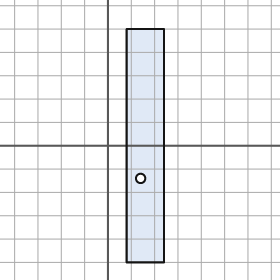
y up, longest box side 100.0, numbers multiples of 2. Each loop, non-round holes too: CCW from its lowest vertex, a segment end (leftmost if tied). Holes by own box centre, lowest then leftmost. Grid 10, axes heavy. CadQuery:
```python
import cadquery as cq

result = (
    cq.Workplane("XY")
    .moveTo(8.0, -50.0)
    .lineTo(24.0, -50.0)
    .lineTo(24.0, 50.0)
    .lineTo(8.0, 50.0)
    .close()
    .moveTo(14.0, -14.0)
    .circle(2.0)
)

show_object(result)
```